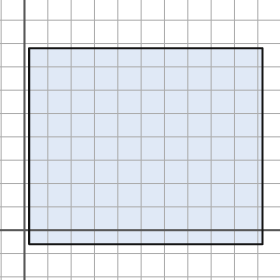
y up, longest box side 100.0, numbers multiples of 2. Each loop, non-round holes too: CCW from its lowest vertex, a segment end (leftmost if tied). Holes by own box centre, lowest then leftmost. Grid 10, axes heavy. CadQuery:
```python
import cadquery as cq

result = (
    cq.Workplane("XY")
    .moveTo(2.0, -6.0)
    .lineTo(102.0, -6.0)
    .lineTo(102.0, 78.0)
    .lineTo(2.0, 78.0)
    .close()
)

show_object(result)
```